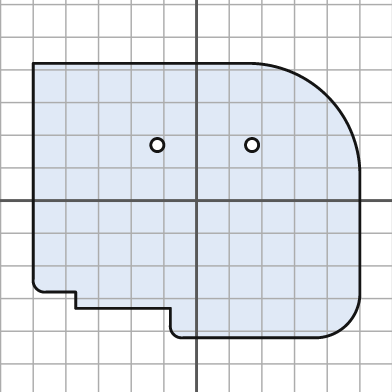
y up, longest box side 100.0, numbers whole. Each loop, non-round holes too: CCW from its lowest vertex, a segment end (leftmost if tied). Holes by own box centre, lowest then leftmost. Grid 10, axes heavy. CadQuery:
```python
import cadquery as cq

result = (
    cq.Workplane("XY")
    .moveTo(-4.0, -42.0)
    .lineTo(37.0, -42.0)
    .threePointArc((46.0, -38.0), (50.0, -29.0))
    .lineTo(50.0, 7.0)
    .threePointArc((40.0, 32.0), (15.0, 42.0))
    .lineTo(-50.0, 42.0)
    .lineTo(-50.0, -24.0)
    .threePointArc((-49.0, -27.0), (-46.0, -28.0))
    .lineTo(-37.0, -28.0)
    .lineTo(-37.0, -33.0)
    .lineTo(-8.0, -33.0)
    .lineTo(-8.0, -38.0)
    .threePointArc((-7.0, -41.0), (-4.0, -42.0))
    .close()
    .moveTo(-12.0, 17.0)
    .circle(2.0)
    .moveTo(17.0, 17.0)
    .circle(2.0)
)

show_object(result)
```